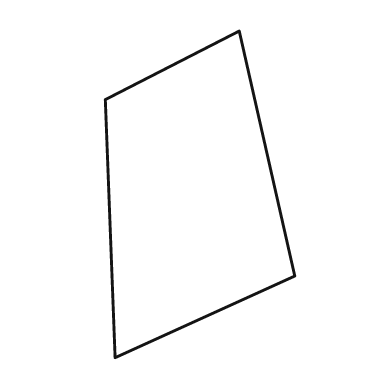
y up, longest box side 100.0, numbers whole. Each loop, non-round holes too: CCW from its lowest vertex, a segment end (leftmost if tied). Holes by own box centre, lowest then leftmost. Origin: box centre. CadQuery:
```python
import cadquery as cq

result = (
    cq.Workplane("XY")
    .moveTo(-26.0, -50.0)
    .lineTo(29.0, -25.0)
    .lineTo(12.0, 50.0)
    .lineTo(-29.0, 29.0)
    .close()
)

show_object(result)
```